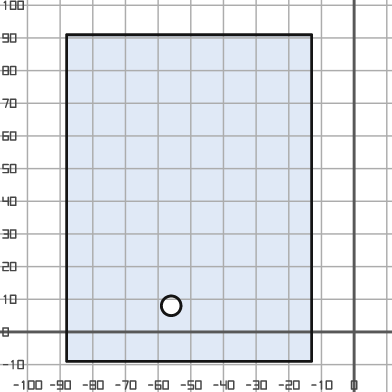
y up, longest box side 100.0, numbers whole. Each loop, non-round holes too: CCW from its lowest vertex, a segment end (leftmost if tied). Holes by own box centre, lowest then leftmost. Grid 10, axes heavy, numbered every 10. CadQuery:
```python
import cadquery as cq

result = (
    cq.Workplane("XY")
    .moveTo(-88.0, -9.0)
    .lineTo(-13.0, -9.0)
    .lineTo(-13.0, 91.0)
    .lineTo(-88.0, 91.0)
    .close()
    .moveTo(-56.0, 8.0)
    .circle(3.0)
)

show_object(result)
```